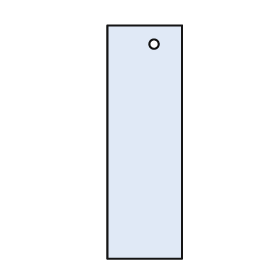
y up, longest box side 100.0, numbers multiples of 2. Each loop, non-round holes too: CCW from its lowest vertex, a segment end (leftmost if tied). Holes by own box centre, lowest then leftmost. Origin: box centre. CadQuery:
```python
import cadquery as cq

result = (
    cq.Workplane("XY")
    .moveTo(-16.0, -50.0)
    .lineTo(16.0, -50.0)
    .lineTo(16.0, 50.0)
    .lineTo(-16.0, 50.0)
    .close()
    .moveTo(4.0, 42.0)
    .circle(2.0)
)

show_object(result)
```